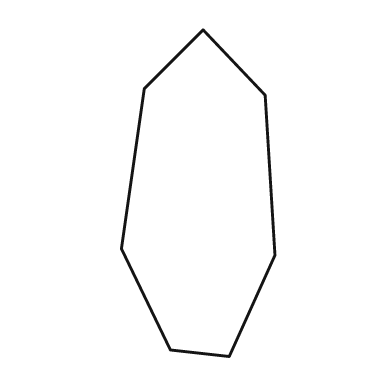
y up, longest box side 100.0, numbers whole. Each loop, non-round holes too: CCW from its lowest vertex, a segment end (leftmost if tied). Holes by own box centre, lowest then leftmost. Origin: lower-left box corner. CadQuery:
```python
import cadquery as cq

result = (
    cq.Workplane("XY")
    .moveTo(33.0, 0.0)
    .lineTo(47.0, 31.0)
    .lineTo(44.0, 80.0)
    .lineTo(25.0, 100.0)
    .lineTo(7.0, 82.0)
    .lineTo(0.0, 33.0)
    .lineTo(15.0, 2.0)
    .close()
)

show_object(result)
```